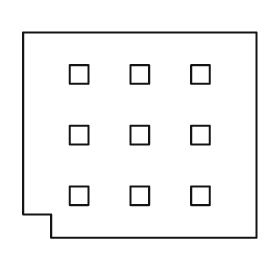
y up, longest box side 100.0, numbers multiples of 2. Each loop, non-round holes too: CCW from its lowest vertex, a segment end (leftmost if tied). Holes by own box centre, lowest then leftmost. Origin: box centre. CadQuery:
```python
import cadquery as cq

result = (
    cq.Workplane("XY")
    .moveTo(-38.0, -44.0)
    .lineTo(50.0, -44.0)
    .lineTo(50.0, 44.0)
    .lineTo(-50.0, 44.0)
    .lineTo(-50.0, -34.0)
    .lineTo(-38.0, -34.0)
    .close()
    .moveTo(-30.0, -30.0)
    .lineTo(-22.0, -30.0)
    .lineTo(-22.0, -22.0)
    .lineTo(-30.0, -22.0)
    .close()
    .moveTo(-4.0, -30.0)
    .lineTo(4.0, -30.0)
    .lineTo(4.0, -22.0)
    .lineTo(-4.0, -22.0)
    .close()
    .moveTo(22.0, -30.0)
    .lineTo(30.0, -30.0)
    .lineTo(30.0, -22.0)
    .lineTo(22.0, -22.0)
    .close()
    .moveTo(-30.0, -4.0)
    .lineTo(-22.0, -4.0)
    .lineTo(-22.0, 4.0)
    .lineTo(-30.0, 4.0)
    .close()
    .moveTo(-4.0, -4.0)
    .lineTo(4.0, -4.0)
    .lineTo(4.0, 4.0)
    .lineTo(-4.0, 4.0)
    .close()
    .moveTo(22.0, -4.0)
    .lineTo(30.0, -4.0)
    .lineTo(30.0, 4.0)
    .lineTo(22.0, 4.0)
    .close()
    .moveTo(-30.0, 22.0)
    .lineTo(-22.0, 22.0)
    .lineTo(-22.0, 30.0)
    .lineTo(-30.0, 30.0)
    .close()
    .moveTo(-4.0, 22.0)
    .lineTo(4.0, 22.0)
    .lineTo(4.0, 30.0)
    .lineTo(-4.0, 30.0)
    .close()
    .moveTo(22.0, 22.0)
    .lineTo(30.0, 22.0)
    .lineTo(30.0, 30.0)
    .lineTo(22.0, 30.0)
    .close()
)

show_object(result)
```